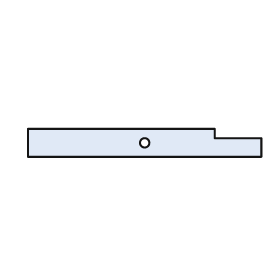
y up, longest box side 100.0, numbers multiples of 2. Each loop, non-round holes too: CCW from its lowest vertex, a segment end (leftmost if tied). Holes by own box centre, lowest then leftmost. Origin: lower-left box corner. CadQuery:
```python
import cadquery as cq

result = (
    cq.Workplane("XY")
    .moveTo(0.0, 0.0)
    .lineTo(100.0, 0.0)
    .lineTo(100.0, 8.0)
    .lineTo(80.0, 8.0)
    .lineTo(80.0, 12.0)
    .lineTo(0.0, 12.0)
    .close()
    .moveTo(50.0, 6.0)
    .circle(2.0)
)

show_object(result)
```